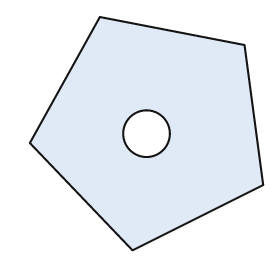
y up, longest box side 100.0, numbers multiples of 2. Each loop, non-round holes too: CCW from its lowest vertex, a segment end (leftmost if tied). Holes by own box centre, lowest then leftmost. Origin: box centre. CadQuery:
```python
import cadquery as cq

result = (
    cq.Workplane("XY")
    .moveTo(-6.0, -50.0)
    .lineTo(50.0, -22.0)
    .lineTo(42.0, 38.0)
    .lineTo(-20.0, 50.0)
    .lineTo(-50.0, -4.0)
    .close()
    .moveTo(0.0, 0.0)
    .circle(10.0)
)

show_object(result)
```